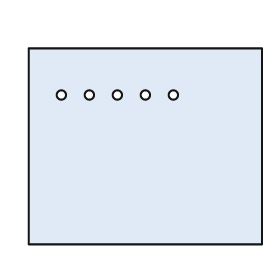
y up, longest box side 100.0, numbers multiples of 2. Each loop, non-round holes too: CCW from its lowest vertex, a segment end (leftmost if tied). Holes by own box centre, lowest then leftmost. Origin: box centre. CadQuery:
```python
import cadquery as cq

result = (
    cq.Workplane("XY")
    .moveTo(-50.0, -42.0)
    .lineTo(50.0, -42.0)
    .lineTo(50.0, 42.0)
    .lineTo(-50.0, 42.0)
    .close()
    .moveTo(-36.0, 22.0)
    .circle(2.0)
    .moveTo(-24.0, 22.0)
    .circle(2.0)
    .moveTo(-12.0, 22.0)
    .circle(2.0)
    .moveTo(0.0, 22.0)
    .circle(2.0)
    .moveTo(12.0, 22.0)
    .circle(2.0)
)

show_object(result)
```